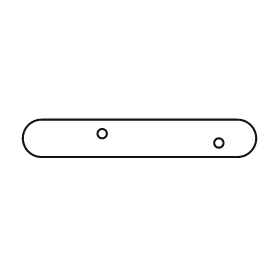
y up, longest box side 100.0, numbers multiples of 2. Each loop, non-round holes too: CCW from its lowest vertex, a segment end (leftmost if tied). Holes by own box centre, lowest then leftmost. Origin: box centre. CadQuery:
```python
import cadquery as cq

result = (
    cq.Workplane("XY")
    .moveTo(-42.0, -8.0)
    .lineTo(42.0, -8.0)
    .threePointArc((50.0, 0.0), (42.0, 8.0))
    .lineTo(-42.0, 8.0)
    .threePointArc((-50.0, 0.0), (-42.0, -8.0))
    .close()
    .moveTo(34.0, -2.0)
    .circle(2.0)
    .moveTo(-16.0, 2.0)
    .circle(2.0)
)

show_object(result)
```